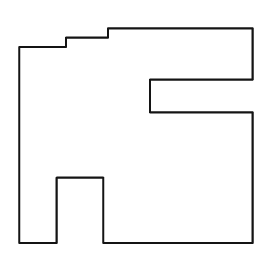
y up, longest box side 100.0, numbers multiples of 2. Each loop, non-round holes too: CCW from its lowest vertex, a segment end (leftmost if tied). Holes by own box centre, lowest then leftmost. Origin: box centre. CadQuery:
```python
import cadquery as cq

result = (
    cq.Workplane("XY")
    .moveTo(-50.0, -46.0)
    .lineTo(-34.0, -46.0)
    .lineTo(-34.0, -18.0)
    .lineTo(-14.0, -18.0)
    .lineTo(-14.0, -46.0)
    .lineTo(50.0, -46.0)
    .lineTo(50.0, 10.0)
    .lineTo(6.0, 10.0)
    .lineTo(6.0, 24.0)
    .lineTo(50.0, 24.0)
    .lineTo(50.0, 46.0)
    .lineTo(-12.0, 46.0)
    .lineTo(-12.0, 42.0)
    .lineTo(-30.0, 42.0)
    .lineTo(-30.0, 38.0)
    .lineTo(-50.0, 38.0)
    .close()
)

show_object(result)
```